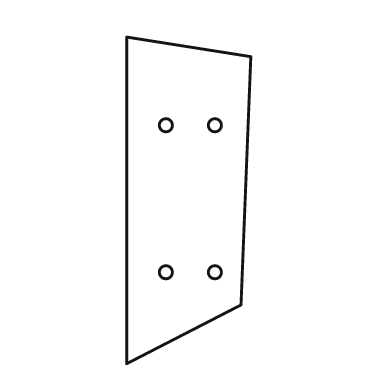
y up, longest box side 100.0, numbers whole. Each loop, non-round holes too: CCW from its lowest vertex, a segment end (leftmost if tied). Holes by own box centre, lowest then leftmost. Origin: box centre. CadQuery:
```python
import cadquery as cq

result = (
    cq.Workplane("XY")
    .moveTo(-19.0, -50.0)
    .lineTo(16.0, -32.0)
    .lineTo(19.0, 44.0)
    .lineTo(-19.0, 50.0)
    .close()
    .moveTo(-7.0, -22.0)
    .circle(2.0)
    .moveTo(8.0, -22.0)
    .circle(2.0)
    .moveTo(-7.0, 23.0)
    .circle(2.0)
    .moveTo(8.0, 23.0)
    .circle(2.0)
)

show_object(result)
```